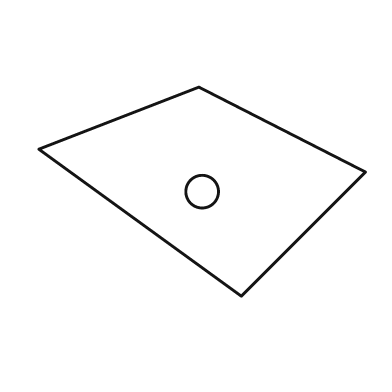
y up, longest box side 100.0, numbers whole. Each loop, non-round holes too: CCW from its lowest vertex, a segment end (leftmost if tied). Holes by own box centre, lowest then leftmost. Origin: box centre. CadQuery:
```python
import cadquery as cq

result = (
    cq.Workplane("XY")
    .moveTo(12.0, -32.0)
    .lineTo(50.0, 6.0)
    .lineTo(-1.0, 32.0)
    .lineTo(-50.0, 13.0)
    .close()
    .moveTo(0.0, 0.0)
    .circle(5.0)
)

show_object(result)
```